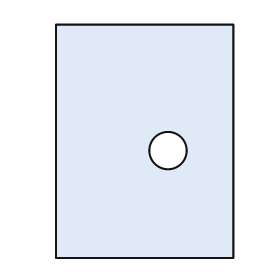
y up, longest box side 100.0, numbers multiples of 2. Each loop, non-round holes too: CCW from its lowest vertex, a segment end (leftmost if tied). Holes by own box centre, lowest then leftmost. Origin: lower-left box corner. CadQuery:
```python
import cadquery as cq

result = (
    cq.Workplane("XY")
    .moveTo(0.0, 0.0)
    .lineTo(76.0, 0.0)
    .lineTo(76.0, 100.0)
    .lineTo(0.0, 100.0)
    .close()
    .moveTo(48.0, 46.0)
    .circle(8.0)
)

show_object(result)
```